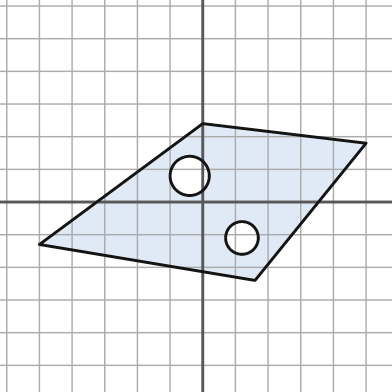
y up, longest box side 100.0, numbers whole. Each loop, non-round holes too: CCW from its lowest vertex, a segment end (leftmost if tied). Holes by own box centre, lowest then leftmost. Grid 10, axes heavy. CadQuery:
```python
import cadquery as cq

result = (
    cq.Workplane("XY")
    .moveTo(16.0, -24.0)
    .lineTo(50.0, 18.0)
    .lineTo(0.0, 24.0)
    .lineTo(-50.0, -13.0)
    .close()
    .moveTo(12.0, -11.0)
    .circle(5.0)
    .moveTo(-4.0, 8.0)
    .circle(6.0)
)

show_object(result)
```